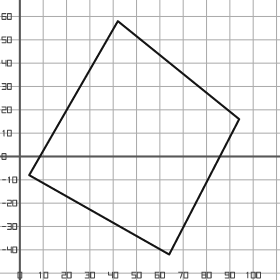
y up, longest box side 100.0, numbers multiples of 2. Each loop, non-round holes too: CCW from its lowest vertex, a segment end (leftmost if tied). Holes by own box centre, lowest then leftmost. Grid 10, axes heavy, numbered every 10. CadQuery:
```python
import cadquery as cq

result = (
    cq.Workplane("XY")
    .moveTo(64.0, -42.0)
    .lineTo(94.0, 16.0)
    .lineTo(42.0, 58.0)
    .lineTo(4.0, -8.0)
    .close()
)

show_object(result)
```